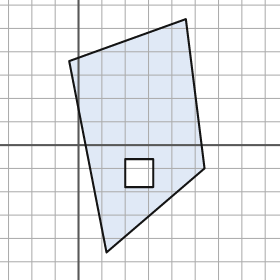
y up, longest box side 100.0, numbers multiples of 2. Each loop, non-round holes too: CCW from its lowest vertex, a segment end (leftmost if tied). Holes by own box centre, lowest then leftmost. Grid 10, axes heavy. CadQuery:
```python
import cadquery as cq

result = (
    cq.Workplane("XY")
    .moveTo(12.0, -46.0)
    .lineTo(54.0, -10.0)
    .lineTo(46.0, 54.0)
    .lineTo(-4.0, 36.0)
    .close()
    .moveTo(20.0, -18.0)
    .lineTo(32.0, -18.0)
    .lineTo(32.0, -6.0)
    .lineTo(20.0, -6.0)
    .close()
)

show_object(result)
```